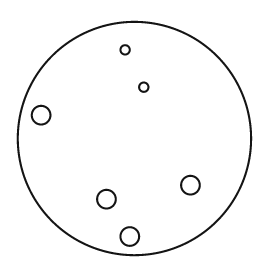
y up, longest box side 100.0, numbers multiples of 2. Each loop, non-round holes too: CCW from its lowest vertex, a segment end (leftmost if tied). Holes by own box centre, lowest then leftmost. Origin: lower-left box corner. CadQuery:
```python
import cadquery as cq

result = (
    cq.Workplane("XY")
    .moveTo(50.0, 50.0)
    .circle(50.0)
    .moveTo(48.0, 8.0)
    .circle(4.0)
    .moveTo(38.0, 24.0)
    .circle(4.0)
    .moveTo(74.0, 30.0)
    .circle(4.0)
    .moveTo(10.0, 60.0)
    .circle(4.0)
    .moveTo(54.0, 72.0)
    .circle(2.0)
    .moveTo(46.0, 88.0)
    .circle(2.0)
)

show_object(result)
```